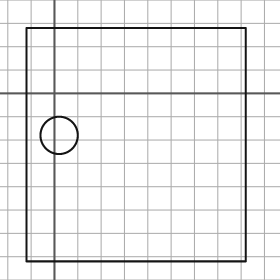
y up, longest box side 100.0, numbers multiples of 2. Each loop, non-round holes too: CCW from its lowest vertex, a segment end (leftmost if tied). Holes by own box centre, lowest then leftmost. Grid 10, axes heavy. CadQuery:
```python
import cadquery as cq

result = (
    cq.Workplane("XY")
    .moveTo(-12.0, -72.0)
    .lineTo(82.0, -72.0)
    .lineTo(82.0, 28.0)
    .lineTo(-12.0, 28.0)
    .close()
    .moveTo(2.0, -18.0)
    .circle(8.0)
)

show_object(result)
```